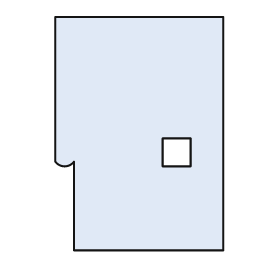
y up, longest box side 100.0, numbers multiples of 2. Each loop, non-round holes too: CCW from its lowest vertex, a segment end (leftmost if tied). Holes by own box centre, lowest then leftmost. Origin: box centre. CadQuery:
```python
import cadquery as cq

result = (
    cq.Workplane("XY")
    .moveTo(-28.0, -50.0)
    .lineTo(36.0, -50.0)
    .lineTo(36.0, 50.0)
    .lineTo(-36.0, 50.0)
    .lineTo(-36.0, -12.0)
    .threePointArc((-32.0, -14.0), (-28.0, -12.0))
    .close()
    .moveTo(10.0, -14.0)
    .lineTo(22.0, -14.0)
    .lineTo(22.0, -2.0)
    .lineTo(10.0, -2.0)
    .close()
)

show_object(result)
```